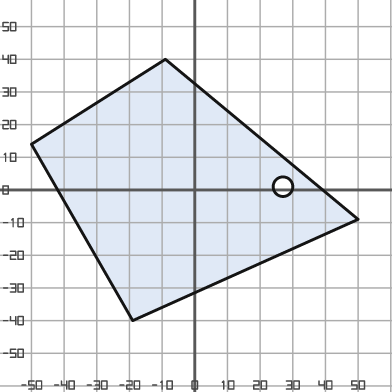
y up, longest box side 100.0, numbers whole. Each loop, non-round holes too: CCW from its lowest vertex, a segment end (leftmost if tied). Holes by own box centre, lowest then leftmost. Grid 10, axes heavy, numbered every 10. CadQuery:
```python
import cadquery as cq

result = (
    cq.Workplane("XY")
    .moveTo(-19.0, -40.0)
    .lineTo(50.0, -9.0)
    .lineTo(-9.0, 40.0)
    .lineTo(-50.0, 14.0)
    .close()
    .moveTo(27.0, 1.0)
    .circle(3.0)
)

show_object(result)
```